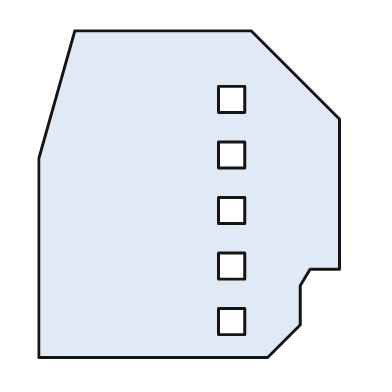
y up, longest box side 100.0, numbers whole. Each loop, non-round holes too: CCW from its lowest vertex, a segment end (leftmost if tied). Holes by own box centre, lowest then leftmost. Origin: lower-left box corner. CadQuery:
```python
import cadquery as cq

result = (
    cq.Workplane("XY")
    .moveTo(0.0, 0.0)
    .lineTo(70.0, 0.0)
    .lineTo(80.0, 10.0)
    .lineTo(80.0, 22.0)
    .lineTo(83.0, 27.0)
    .lineTo(92.0, 27.0)
    .lineTo(92.0, 73.0)
    .lineTo(65.0, 100.0)
    .lineTo(11.0, 100.0)
    .lineTo(0.0, 61.0)
    .close()
    .moveTo(55.0, 7.0)
    .lineTo(63.0, 7.0)
    .lineTo(63.0, 15.0)
    .lineTo(55.0, 15.0)
    .close()
    .moveTo(55.0, 24.0)
    .lineTo(63.0, 24.0)
    .lineTo(63.0, 32.0)
    .lineTo(55.0, 32.0)
    .close()
    .moveTo(55.0, 41.0)
    .lineTo(63.0, 41.0)
    .lineTo(63.0, 49.0)
    .lineTo(55.0, 49.0)
    .close()
    .moveTo(55.0, 58.0)
    .lineTo(63.0, 58.0)
    .lineTo(63.0, 66.0)
    .lineTo(55.0, 66.0)
    .close()
    .moveTo(55.0, 75.0)
    .lineTo(63.0, 75.0)
    .lineTo(63.0, 83.0)
    .lineTo(55.0, 83.0)
    .close()
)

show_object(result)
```